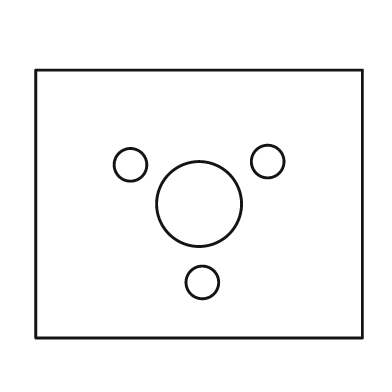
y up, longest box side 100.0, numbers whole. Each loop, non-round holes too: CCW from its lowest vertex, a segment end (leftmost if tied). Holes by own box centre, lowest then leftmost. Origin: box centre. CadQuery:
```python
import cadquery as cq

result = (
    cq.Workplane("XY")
    .moveTo(-50.0, -41.0)
    .lineTo(50.0, -41.0)
    .lineTo(50.0, 41.0)
    .lineTo(-50.0, 41.0)
    .close()
    .moveTo(1.0, -24.0)
    .circle(5.0)
    .moveTo(0.0, 0.0)
    .circle(13.0)
    .moveTo(-21.0, 12.0)
    .circle(5.0)
    .moveTo(21.0, 13.0)
    .circle(5.0)
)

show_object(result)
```